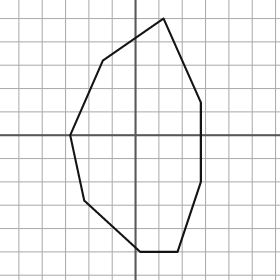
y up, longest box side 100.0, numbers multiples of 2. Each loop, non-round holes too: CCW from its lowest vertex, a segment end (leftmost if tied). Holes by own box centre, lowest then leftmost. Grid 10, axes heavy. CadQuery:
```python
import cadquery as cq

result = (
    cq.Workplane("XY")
    .moveTo(2.0, -50.0)
    .lineTo(18.0, -50.0)
    .lineTo(28.0, -20.0)
    .lineTo(28.0, 14.0)
    .lineTo(12.0, 50.0)
    .lineTo(-14.0, 32.0)
    .lineTo(-28.0, 0.0)
    .lineTo(-22.0, -28.0)
    .close()
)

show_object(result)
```